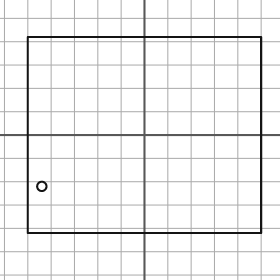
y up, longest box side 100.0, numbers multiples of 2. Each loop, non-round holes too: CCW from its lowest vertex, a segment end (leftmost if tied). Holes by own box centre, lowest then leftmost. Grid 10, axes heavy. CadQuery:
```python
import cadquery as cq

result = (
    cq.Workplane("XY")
    .moveTo(-50.0, -42.0)
    .lineTo(50.0, -42.0)
    .lineTo(50.0, 42.0)
    .lineTo(-50.0, 42.0)
    .close()
    .moveTo(-44.0, -22.0)
    .circle(2.0)
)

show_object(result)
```